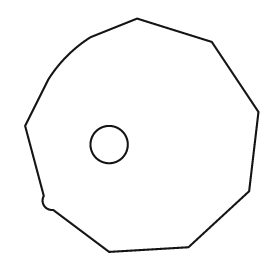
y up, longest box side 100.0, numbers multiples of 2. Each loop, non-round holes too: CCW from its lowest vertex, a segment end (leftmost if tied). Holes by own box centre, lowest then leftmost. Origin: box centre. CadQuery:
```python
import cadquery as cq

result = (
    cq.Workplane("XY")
    .moveTo(-14.0, -50.0)
    .lineTo(20.0, -48.0)
    .lineTo(46.0, -24.0)
    .lineTo(50.0, 10.0)
    .lineTo(30.0, 40.0)
    .lineTo(-2.0, 50.0)
    .lineTo(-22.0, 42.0)
    .threePointArc((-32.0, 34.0), (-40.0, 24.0))
    .lineTo(-50.0, 4.0)
    .lineTo(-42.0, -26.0)
    .threePointArc((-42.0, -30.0), (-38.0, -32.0))
    .close()
    .moveTo(-14.0, -4.0)
    .circle(8.0)
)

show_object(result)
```